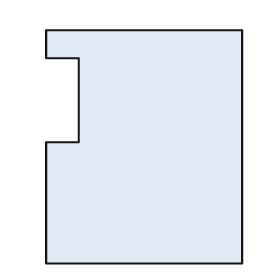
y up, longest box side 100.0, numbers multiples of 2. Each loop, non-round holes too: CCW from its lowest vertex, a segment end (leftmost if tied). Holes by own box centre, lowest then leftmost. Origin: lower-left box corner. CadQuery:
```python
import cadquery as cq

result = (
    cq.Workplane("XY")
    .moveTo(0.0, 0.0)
    .lineTo(84.0, 0.0)
    .lineTo(84.0, 100.0)
    .lineTo(0.0, 100.0)
    .lineTo(0.0, 88.0)
    .lineTo(14.0, 88.0)
    .lineTo(14.0, 52.0)
    .lineTo(0.0, 52.0)
    .close()
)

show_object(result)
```